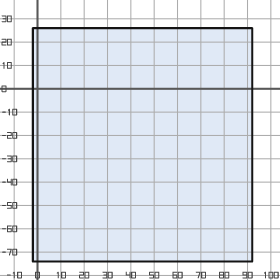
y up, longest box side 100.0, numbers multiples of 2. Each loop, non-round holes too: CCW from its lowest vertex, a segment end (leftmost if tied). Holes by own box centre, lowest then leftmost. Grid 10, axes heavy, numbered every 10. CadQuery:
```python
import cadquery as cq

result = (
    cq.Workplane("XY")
    .moveTo(-2.0, -74.0)
    .lineTo(92.0, -74.0)
    .lineTo(92.0, 26.0)
    .lineTo(-2.0, 26.0)
    .close()
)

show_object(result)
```